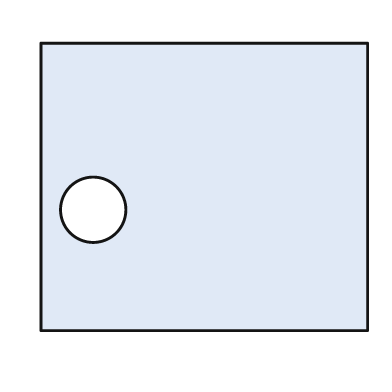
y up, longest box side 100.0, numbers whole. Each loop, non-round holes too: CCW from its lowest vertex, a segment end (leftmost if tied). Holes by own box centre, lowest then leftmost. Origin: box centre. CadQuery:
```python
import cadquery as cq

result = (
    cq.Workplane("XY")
    .moveTo(-50.0, -44.0)
    .lineTo(50.0, -44.0)
    .lineTo(50.0, 44.0)
    .lineTo(-50.0, 44.0)
    .close()
    .moveTo(-34.0, -7.0)
    .circle(10.0)
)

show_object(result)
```